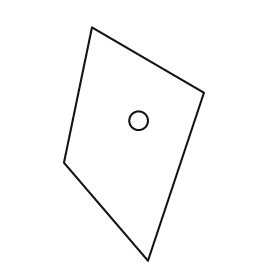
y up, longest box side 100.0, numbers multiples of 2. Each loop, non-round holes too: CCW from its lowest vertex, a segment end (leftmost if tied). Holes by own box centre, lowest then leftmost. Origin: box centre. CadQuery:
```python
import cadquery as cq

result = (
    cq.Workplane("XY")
    .moveTo(6.0, -50.0)
    .lineTo(30.0, 22.0)
    .lineTo(-18.0, 50.0)
    .lineTo(-30.0, -8.0)
    .close()
    .moveTo(2.0, 10.0)
    .circle(4.0)
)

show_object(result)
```